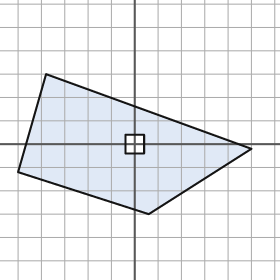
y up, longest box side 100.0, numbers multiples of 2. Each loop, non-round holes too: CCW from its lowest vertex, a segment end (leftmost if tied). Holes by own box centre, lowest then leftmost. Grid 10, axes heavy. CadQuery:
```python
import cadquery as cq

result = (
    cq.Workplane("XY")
    .moveTo(6.0, -30.0)
    .lineTo(50.0, -2.0)
    .lineTo(-38.0, 30.0)
    .lineTo(-50.0, -12.0)
    .close()
    .moveTo(-4.0, -4.0)
    .lineTo(4.0, -4.0)
    .lineTo(4.0, 4.0)
    .lineTo(-4.0, 4.0)
    .close()
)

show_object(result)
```